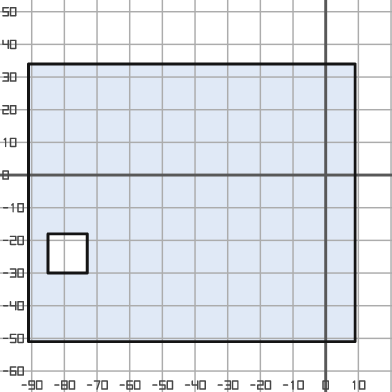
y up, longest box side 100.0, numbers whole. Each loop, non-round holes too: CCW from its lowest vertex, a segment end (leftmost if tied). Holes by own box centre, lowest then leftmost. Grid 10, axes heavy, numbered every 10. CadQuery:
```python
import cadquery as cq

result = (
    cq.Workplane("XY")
    .moveTo(-91.0, -51.0)
    .lineTo(9.0, -51.0)
    .lineTo(9.0, 34.0)
    .lineTo(-91.0, 34.0)
    .close()
    .moveTo(-85.0, -30.0)
    .lineTo(-73.0, -30.0)
    .lineTo(-73.0, -18.0)
    .lineTo(-85.0, -18.0)
    .close()
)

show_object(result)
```